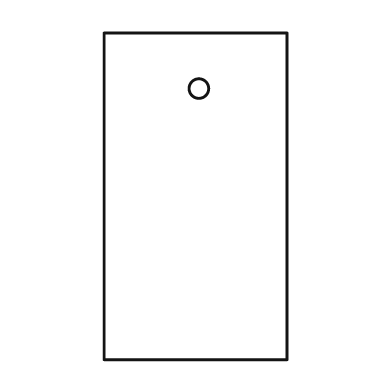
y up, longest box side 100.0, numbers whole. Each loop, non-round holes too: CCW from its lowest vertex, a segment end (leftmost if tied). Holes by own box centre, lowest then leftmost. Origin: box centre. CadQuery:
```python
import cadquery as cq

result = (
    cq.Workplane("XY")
    .moveTo(-28.0, -50.0)
    .lineTo(28.0, -50.0)
    .lineTo(28.0, 50.0)
    .lineTo(-28.0, 50.0)
    .close()
    .moveTo(1.0, 33.0)
    .circle(3.0)
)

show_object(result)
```